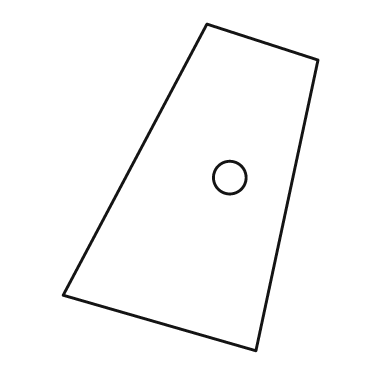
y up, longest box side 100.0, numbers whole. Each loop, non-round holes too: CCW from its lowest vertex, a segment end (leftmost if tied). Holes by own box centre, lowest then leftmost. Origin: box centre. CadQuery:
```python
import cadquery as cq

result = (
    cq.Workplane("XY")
    .moveTo(20.0, -50.0)
    .lineTo(39.0, 39.0)
    .lineTo(5.0, 50.0)
    .lineTo(-39.0, -33.0)
    .close()
    .moveTo(12.0, 3.0)
    .circle(5.0)
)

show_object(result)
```